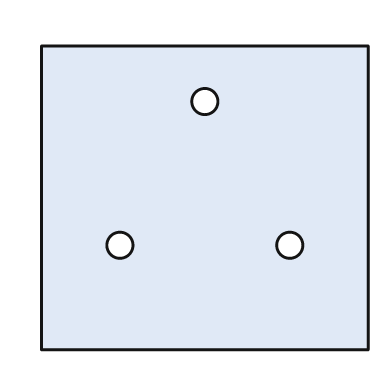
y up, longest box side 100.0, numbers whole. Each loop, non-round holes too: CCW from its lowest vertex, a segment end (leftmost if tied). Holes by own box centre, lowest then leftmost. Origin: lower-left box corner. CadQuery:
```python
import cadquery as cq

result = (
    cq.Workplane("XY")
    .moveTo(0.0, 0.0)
    .lineTo(100.0, 0.0)
    .lineTo(100.0, 93.0)
    .lineTo(0.0, 93.0)
    .close()
    .moveTo(24.0, 32.0)
    .circle(4.0)
    .moveTo(76.0, 32.0)
    .circle(4.0)
    .moveTo(50.0, 76.0)
    .circle(4.0)
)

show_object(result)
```